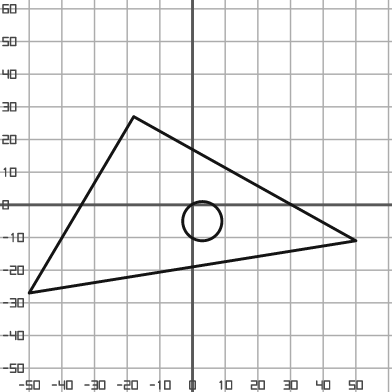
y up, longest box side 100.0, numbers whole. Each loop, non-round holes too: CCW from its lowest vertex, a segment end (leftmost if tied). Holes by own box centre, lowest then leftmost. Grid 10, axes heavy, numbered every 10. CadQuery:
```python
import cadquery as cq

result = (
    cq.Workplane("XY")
    .moveTo(-50.0, -27.0)
    .lineTo(50.0, -11.0)
    .lineTo(-18.0, 27.0)
    .close()
    .moveTo(3.0, -5.0)
    .circle(6.0)
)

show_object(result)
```